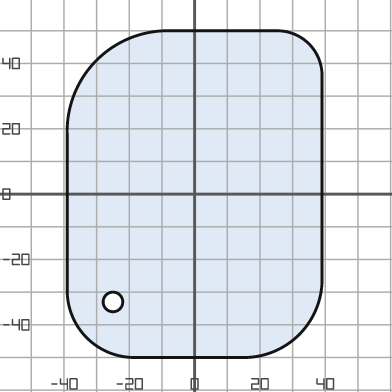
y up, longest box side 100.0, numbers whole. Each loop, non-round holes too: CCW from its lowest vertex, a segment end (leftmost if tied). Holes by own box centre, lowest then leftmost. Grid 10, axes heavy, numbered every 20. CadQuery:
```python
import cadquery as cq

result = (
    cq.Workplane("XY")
    .moveTo(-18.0, -50.0)
    .lineTo(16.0, -50.0)
    .threePointArc((32.0, -43.0), (39.0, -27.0))
    .lineTo(39.0, 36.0)
    .threePointArc((35.0, 46.0), (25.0, 50.0))
    .lineTo(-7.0, 50.0)
    .threePointArc((-30.0, 41.0), (-39.0, 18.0))
    .lineTo(-39.0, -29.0)
    .threePointArc((-33.0, -44.0), (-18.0, -50.0))
    .close()
    .moveTo(-25.0, -33.0)
    .circle(3.0)
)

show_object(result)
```